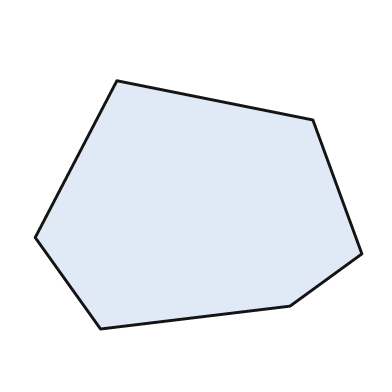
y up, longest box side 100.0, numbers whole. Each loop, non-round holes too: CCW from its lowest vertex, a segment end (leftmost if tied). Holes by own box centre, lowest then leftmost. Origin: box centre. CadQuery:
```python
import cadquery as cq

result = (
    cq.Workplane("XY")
    .moveTo(-30.0, -38.0)
    .lineTo(28.0, -31.0)
    .lineTo(50.0, -15.0)
    .lineTo(35.0, 26.0)
    .lineTo(-25.0, 38.0)
    .lineTo(-50.0, -10.0)
    .close()
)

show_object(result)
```